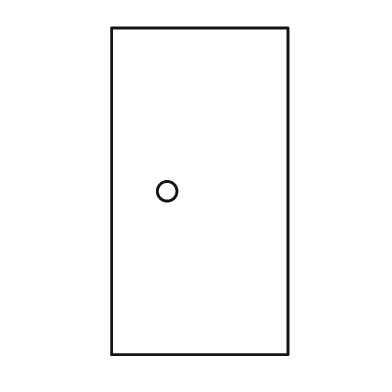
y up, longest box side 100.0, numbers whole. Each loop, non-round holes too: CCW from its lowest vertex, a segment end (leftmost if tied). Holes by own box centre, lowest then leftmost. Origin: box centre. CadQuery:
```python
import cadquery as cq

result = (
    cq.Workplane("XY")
    .moveTo(-27.0, -50.0)
    .lineTo(27.0, -50.0)
    .lineTo(27.0, 50.0)
    .lineTo(-27.0, 50.0)
    .close()
    .moveTo(-10.0, 0.0)
    .circle(3.0)
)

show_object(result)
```